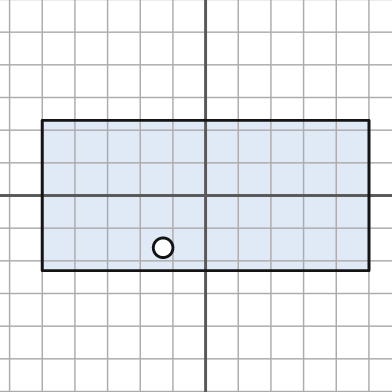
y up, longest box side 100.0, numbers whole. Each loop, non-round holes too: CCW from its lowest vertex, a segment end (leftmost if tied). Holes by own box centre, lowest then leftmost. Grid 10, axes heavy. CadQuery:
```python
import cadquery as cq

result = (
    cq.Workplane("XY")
    .moveTo(-50.0, -23.0)
    .lineTo(50.0, -23.0)
    .lineTo(50.0, 23.0)
    .lineTo(-50.0, 23.0)
    .close()
    .moveTo(-13.0, -16.0)
    .circle(3.0)
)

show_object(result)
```